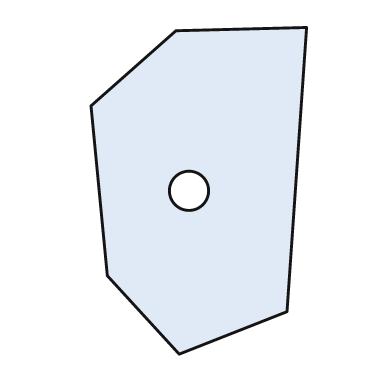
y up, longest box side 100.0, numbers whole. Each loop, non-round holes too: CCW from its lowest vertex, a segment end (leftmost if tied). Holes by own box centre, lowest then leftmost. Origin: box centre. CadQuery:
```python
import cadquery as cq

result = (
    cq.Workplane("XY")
    .moveTo(-6.0, -50.0)
    .lineTo(27.0, -37.0)
    .lineTo(33.0, 50.0)
    .lineTo(-7.0, 49.0)
    .lineTo(-33.0, 26.0)
    .lineTo(-28.0, -26.0)
    .close()
    .moveTo(-3.0, 0.0)
    .circle(6.0)
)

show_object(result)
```